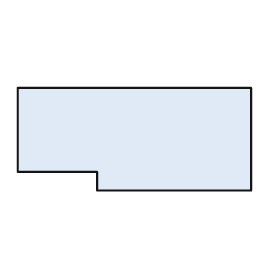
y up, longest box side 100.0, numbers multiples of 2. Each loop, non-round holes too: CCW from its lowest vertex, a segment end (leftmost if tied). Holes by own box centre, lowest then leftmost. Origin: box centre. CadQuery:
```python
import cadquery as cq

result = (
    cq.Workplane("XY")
    .moveTo(-16.0, -22.0)
    .lineTo(50.0, -22.0)
    .lineTo(50.0, 22.0)
    .lineTo(-50.0, 22.0)
    .lineTo(-50.0, -14.0)
    .lineTo(-16.0, -14.0)
    .close()
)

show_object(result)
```